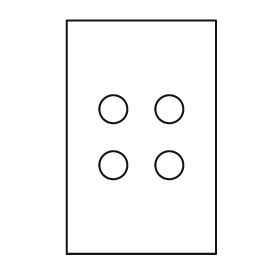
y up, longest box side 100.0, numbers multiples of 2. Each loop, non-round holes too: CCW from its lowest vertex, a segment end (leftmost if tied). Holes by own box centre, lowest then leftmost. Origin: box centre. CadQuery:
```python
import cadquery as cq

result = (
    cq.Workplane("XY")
    .moveTo(-32.0, -50.0)
    .lineTo(32.0, -50.0)
    .lineTo(32.0, 50.0)
    .lineTo(-32.0, 50.0)
    .close()
    .moveTo(-12.0, -12.0)
    .circle(6.0)
    .moveTo(12.0, -12.0)
    .circle(6.0)
    .moveTo(-12.0, 12.0)
    .circle(6.0)
    .moveTo(12.0, 12.0)
    .circle(6.0)
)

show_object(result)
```